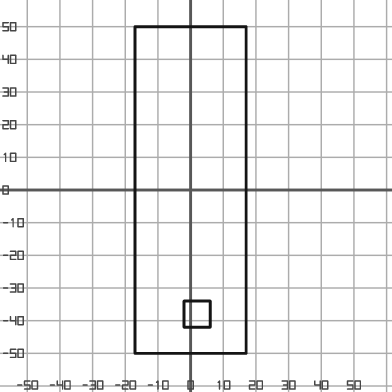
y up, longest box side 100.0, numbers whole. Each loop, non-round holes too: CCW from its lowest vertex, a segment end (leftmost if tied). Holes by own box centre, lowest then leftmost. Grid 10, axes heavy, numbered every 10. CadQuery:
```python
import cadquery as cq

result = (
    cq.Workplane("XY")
    .moveTo(-17.0, -50.0)
    .lineTo(17.0, -50.0)
    .lineTo(17.0, 50.0)
    .lineTo(-17.0, 50.0)
    .close()
    .moveTo(-2.0, -42.0)
    .lineTo(6.0, -42.0)
    .lineTo(6.0, -34.0)
    .lineTo(-2.0, -34.0)
    .close()
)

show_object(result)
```